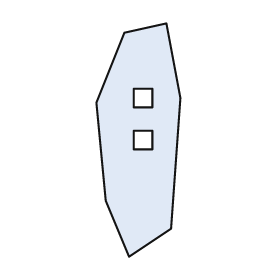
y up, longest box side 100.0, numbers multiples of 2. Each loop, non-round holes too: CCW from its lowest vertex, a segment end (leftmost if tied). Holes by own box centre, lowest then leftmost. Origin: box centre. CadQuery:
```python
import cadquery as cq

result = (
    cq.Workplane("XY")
    .moveTo(-4.0, -50.0)
    .lineTo(14.0, -38.0)
    .lineTo(18.0, 18.0)
    .lineTo(12.0, 50.0)
    .lineTo(-6.0, 46.0)
    .lineTo(-18.0, 16.0)
    .lineTo(-14.0, -26.0)
    .close()
    .moveTo(-2.0, -4.0)
    .lineTo(6.0, -4.0)
    .lineTo(6.0, 4.0)
    .lineTo(-2.0, 4.0)
    .close()
    .moveTo(-2.0, 14.0)
    .lineTo(6.0, 14.0)
    .lineTo(6.0, 22.0)
    .lineTo(-2.0, 22.0)
    .close()
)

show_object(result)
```